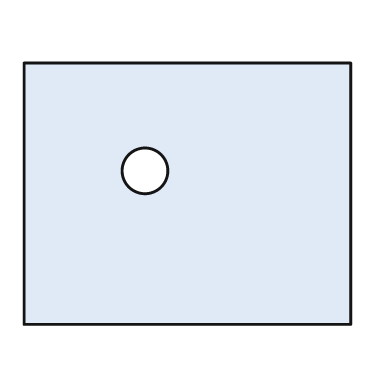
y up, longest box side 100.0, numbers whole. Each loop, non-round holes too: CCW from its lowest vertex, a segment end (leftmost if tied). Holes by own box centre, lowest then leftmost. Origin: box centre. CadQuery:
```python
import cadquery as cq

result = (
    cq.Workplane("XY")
    .moveTo(-50.0, -40.0)
    .lineTo(50.0, -40.0)
    .lineTo(50.0, 40.0)
    .lineTo(-50.0, 40.0)
    .close()
    .moveTo(-13.0, 7.0)
    .circle(7.0)
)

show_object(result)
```